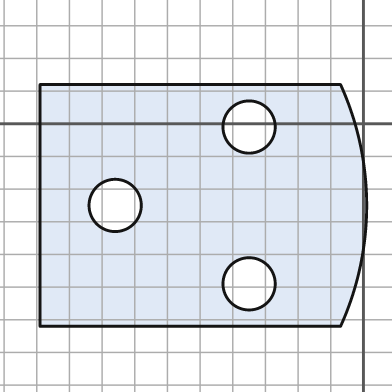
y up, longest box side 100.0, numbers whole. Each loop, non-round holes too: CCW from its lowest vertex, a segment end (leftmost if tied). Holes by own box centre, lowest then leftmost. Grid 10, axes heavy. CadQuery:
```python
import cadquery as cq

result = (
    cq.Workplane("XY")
    .moveTo(-99.0, -62.0)
    .lineTo(-7.0, -62.0)
    .threePointArc((1.0, -25.0), (-7.0, 12.0))
    .lineTo(-99.0, 12.0)
    .close()
    .moveTo(-35.0, -49.0)
    .circle(8.0)
    .moveTo(-76.0, -25.0)
    .circle(8.0)
    .moveTo(-35.0, -1.0)
    .circle(8.0)
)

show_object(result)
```